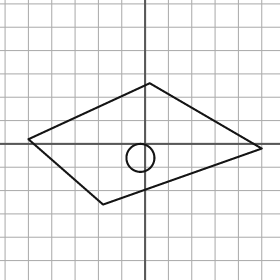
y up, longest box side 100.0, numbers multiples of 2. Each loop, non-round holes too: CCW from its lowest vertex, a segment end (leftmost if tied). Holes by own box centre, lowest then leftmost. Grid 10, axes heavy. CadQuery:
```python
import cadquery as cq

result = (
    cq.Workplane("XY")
    .moveTo(-18.0, -26.0)
    .lineTo(50.0, -2.0)
    .lineTo(2.0, 26.0)
    .lineTo(-50.0, 2.0)
    .close()
    .moveTo(-2.0, -6.0)
    .circle(6.0)
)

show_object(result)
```